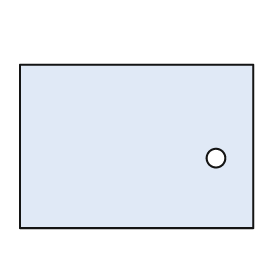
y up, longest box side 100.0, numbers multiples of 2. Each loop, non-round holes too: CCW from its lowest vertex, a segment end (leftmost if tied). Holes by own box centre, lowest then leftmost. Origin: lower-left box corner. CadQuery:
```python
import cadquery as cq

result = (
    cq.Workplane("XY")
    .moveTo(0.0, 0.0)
    .lineTo(100.0, 0.0)
    .lineTo(100.0, 70.0)
    .lineTo(0.0, 70.0)
    .close()
    .moveTo(84.0, 30.0)
    .circle(4.0)
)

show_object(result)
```